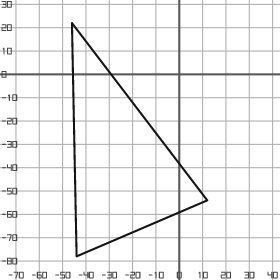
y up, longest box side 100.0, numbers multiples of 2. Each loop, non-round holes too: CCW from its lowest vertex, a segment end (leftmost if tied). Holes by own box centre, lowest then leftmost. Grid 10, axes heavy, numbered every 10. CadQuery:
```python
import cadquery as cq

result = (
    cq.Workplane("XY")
    .moveTo(-44.0, -78.0)
    .lineTo(12.0, -54.0)
    .lineTo(-46.0, 22.0)
    .close()
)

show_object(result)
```